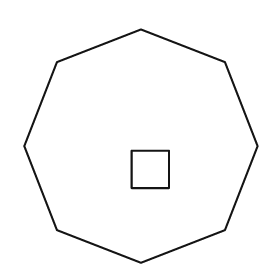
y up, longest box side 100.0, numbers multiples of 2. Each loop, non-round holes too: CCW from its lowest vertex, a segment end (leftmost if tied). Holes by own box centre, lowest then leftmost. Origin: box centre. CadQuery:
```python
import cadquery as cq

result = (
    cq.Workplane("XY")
    .moveTo(0.0, -50.0)
    .lineTo(36.0, -36.0)
    .lineTo(50.0, 0.0)
    .lineTo(36.0, 36.0)
    .lineTo(0.0, 50.0)
    .lineTo(-36.0, 36.0)
    .lineTo(-50.0, 0.0)
    .lineTo(-36.0, -36.0)
    .close()
    .moveTo(-4.0, -18.0)
    .lineTo(12.0, -18.0)
    .lineTo(12.0, -2.0)
    .lineTo(-4.0, -2.0)
    .close()
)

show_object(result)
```